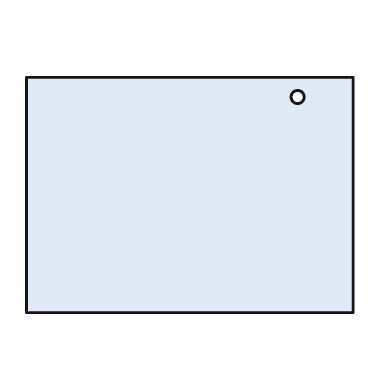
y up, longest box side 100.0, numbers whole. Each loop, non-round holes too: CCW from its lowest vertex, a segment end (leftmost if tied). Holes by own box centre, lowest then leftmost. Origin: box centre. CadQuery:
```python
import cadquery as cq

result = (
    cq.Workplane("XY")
    .moveTo(-50.0, -36.0)
    .lineTo(50.0, -36.0)
    .lineTo(50.0, 36.0)
    .lineTo(-50.0, 36.0)
    .close()
    .moveTo(33.0, 30.0)
    .circle(2.0)
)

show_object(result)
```